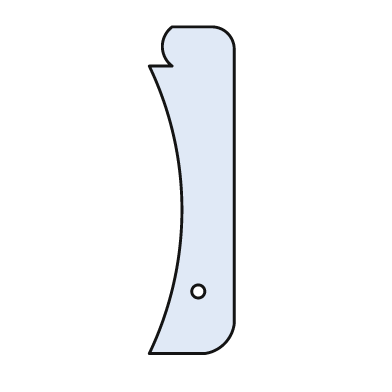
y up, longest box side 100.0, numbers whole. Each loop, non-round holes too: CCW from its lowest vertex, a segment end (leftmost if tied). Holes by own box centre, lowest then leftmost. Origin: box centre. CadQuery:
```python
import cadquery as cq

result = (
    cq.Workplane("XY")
    .moveTo(-13.0, -50.0)
    .lineTo(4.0, -50.0)
    .threePointArc((10.0, -47.0), (13.0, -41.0))
    .lineTo(13.0, 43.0)
    .threePointArc((11.0, 48.0), (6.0, 50.0))
    .lineTo(-6.0, 50.0)
    .threePointArc((-9.0, 44.0), (-6.0, 38.0))
    .lineTo(-13.0, 38.0)
    .threePointArc((-3.0, -6.0), (-13.0, -50.0))
    .close()
    .moveTo(2.0, -31.0)
    .circle(2.0)
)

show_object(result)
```